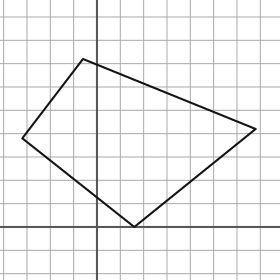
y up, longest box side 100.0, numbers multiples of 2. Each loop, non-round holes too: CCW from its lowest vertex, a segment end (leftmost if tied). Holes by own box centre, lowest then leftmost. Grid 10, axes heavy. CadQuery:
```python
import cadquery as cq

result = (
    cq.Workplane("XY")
    .moveTo(16.0, 0.0)
    .lineTo(68.0, 42.0)
    .lineTo(-6.0, 72.0)
    .lineTo(-32.0, 38.0)
    .close()
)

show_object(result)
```